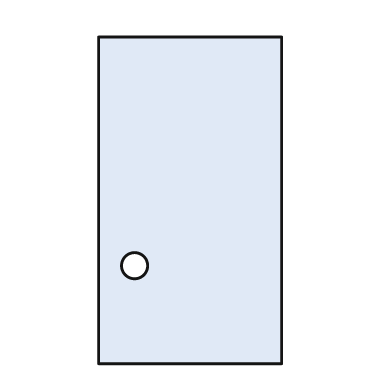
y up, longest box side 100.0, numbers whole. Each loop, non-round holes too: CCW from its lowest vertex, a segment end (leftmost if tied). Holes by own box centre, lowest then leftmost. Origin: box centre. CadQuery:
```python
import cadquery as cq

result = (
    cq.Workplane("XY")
    .moveTo(-28.0, -50.0)
    .lineTo(28.0, -50.0)
    .lineTo(28.0, 50.0)
    .lineTo(-28.0, 50.0)
    .close()
    .moveTo(-17.0, -20.0)
    .circle(4.0)
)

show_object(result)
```